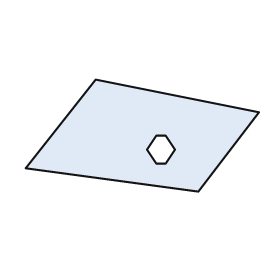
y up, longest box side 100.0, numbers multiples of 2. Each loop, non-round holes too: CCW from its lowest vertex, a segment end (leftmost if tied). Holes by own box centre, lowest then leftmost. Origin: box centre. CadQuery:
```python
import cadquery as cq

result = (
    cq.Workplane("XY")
    .moveTo(24.0, -24.0)
    .lineTo(50.0, 10.0)
    .lineTo(-20.0, 24.0)
    .lineTo(-50.0, -14.0)
    .close()
    .moveTo(6.0, -12.0)
    .lineTo(10.0, -12.0)
    .lineTo(14.0, -6.0)
    .lineTo(10.0, 0.0)
    .lineTo(6.0, 0.0)
    .lineTo(2.0, -6.0)
    .close()
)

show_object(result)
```